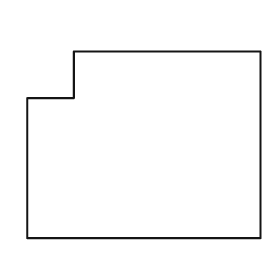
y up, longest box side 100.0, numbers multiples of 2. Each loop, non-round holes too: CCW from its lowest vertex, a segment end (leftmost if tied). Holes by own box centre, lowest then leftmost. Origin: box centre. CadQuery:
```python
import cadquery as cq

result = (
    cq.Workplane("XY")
    .moveTo(-50.0, -40.0)
    .lineTo(50.0, -40.0)
    .lineTo(50.0, 40.0)
    .lineTo(-30.0, 40.0)
    .lineTo(-30.0, 20.0)
    .lineTo(-50.0, 20.0)
    .close()
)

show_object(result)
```